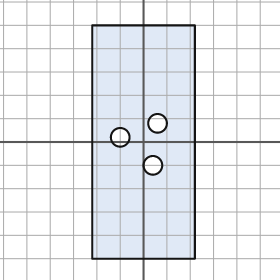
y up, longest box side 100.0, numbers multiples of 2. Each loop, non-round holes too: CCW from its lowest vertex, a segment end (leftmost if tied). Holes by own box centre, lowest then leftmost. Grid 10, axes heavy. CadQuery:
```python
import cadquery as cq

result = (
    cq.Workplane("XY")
    .moveTo(-22.0, -50.0)
    .lineTo(22.0, -50.0)
    .lineTo(22.0, 50.0)
    .lineTo(-22.0, 50.0)
    .close()
    .moveTo(4.0, -10.0)
    .circle(4.0)
    .moveTo(-10.0, 2.0)
    .circle(4.0)
    .moveTo(6.0, 8.0)
    .circle(4.0)
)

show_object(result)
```